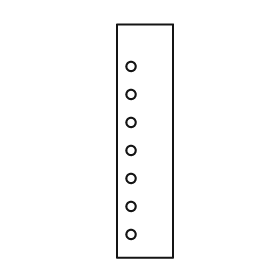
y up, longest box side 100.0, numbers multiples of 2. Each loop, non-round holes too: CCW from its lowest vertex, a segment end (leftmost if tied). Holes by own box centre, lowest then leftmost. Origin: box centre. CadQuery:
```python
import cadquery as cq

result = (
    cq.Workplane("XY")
    .moveTo(-12.0, -50.0)
    .lineTo(12.0, -50.0)
    .lineTo(12.0, 50.0)
    .lineTo(-12.0, 50.0)
    .close()
    .moveTo(-6.0, -40.0)
    .circle(2.0)
    .moveTo(-6.0, -28.0)
    .circle(2.0)
    .moveTo(-6.0, -16.0)
    .circle(2.0)
    .moveTo(-6.0, -4.0)
    .circle(2.0)
    .moveTo(-6.0, 8.0)
    .circle(2.0)
    .moveTo(-6.0, 20.0)
    .circle(2.0)
    .moveTo(-6.0, 32.0)
    .circle(2.0)
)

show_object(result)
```